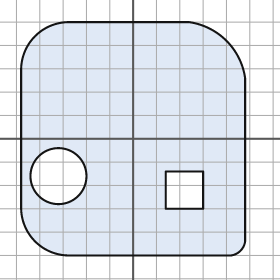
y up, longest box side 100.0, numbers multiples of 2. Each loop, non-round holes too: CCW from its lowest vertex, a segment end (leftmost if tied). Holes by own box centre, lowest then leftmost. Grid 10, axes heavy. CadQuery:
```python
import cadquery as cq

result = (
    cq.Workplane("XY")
    .moveTo(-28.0, -50.0)
    .lineTo(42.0, -50.0)
    .threePointArc((46.0, -48.0), (48.0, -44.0))
    .lineTo(48.0, 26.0)
    .threePointArc((40.0, 42.0), (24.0, 50.0))
    .lineTo(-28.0, 50.0)
    .threePointArc((-42.0, 44.0), (-48.0, 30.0))
    .lineTo(-48.0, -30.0)
    .threePointArc((-42.0, -44.0), (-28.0, -50.0))
    .close()
    .moveTo(14.0, -30.0)
    .lineTo(30.0, -30.0)
    .lineTo(30.0, -14.0)
    .lineTo(14.0, -14.0)
    .close()
    .moveTo(-32.0, -16.0)
    .circle(12.0)
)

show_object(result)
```